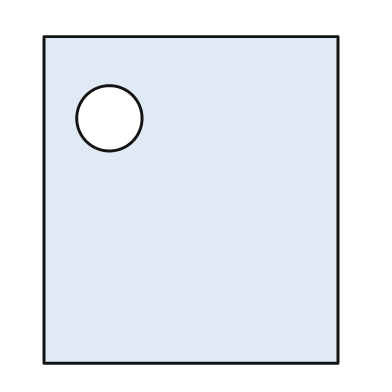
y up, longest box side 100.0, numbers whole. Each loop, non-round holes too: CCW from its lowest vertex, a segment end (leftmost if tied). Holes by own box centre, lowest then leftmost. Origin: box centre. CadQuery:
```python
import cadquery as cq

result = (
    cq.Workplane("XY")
    .moveTo(-45.0, -50.0)
    .lineTo(45.0, -50.0)
    .lineTo(45.0, 50.0)
    .lineTo(-45.0, 50.0)
    .close()
    .moveTo(-25.0, 25.0)
    .circle(10.0)
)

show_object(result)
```